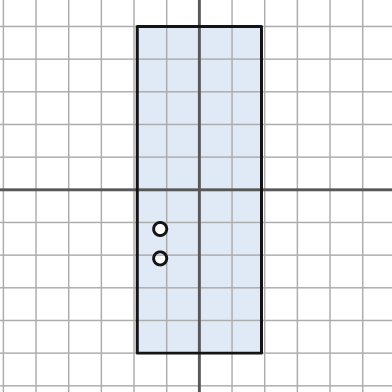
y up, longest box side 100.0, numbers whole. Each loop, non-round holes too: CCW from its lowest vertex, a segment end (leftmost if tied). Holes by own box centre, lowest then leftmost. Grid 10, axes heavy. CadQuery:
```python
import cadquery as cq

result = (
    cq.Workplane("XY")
    .moveTo(-19.0, -50.0)
    .lineTo(19.0, -50.0)
    .lineTo(19.0, 50.0)
    .lineTo(-19.0, 50.0)
    .close()
    .moveTo(-12.0, -21.0)
    .circle(2.0)
    .moveTo(-12.0, -12.0)
    .circle(2.0)
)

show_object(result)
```